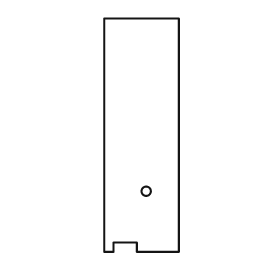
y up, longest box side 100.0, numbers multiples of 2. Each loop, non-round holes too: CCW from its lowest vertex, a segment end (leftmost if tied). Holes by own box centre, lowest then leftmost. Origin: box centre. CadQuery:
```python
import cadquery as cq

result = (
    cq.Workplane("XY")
    .moveTo(-16.0, -50.0)
    .lineTo(-12.0, -50.0)
    .lineTo(-12.0, -46.0)
    .lineTo(-2.0, -46.0)
    .lineTo(-2.0, -50.0)
    .lineTo(16.0, -50.0)
    .lineTo(16.0, 50.0)
    .lineTo(-16.0, 50.0)
    .close()
    .moveTo(2.0, -24.0)
    .circle(2.0)
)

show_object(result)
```